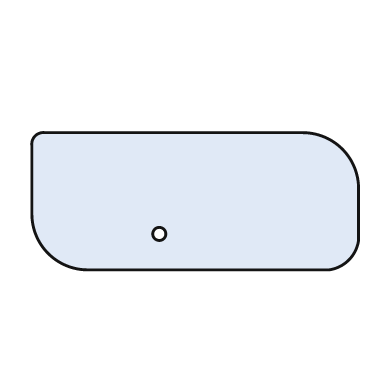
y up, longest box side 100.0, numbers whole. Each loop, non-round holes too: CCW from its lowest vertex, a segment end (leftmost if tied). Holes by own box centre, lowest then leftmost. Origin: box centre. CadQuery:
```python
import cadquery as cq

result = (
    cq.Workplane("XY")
    .moveTo(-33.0, -21.0)
    .lineTo(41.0, -21.0)
    .threePointArc((47.0, -18.0), (50.0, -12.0))
    .lineTo(50.0, 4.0)
    .threePointArc((45.0, 16.0), (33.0, 21.0))
    .lineTo(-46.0, 21.0)
    .threePointArc((-49.0, 20.0), (-50.0, 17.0))
    .lineTo(-50.0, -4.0)
    .threePointArc((-45.0, -16.0), (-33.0, -21.0))
    .close()
    .moveTo(-11.0, -10.0)
    .circle(2.0)
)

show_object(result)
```